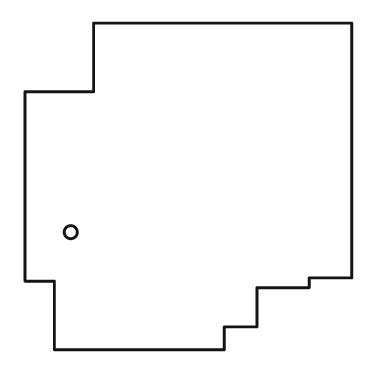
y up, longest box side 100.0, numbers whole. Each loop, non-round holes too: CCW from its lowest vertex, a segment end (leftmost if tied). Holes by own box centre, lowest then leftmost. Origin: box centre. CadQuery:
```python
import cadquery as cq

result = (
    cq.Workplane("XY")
    .moveTo(-41.0, -50.0)
    .lineTo(11.0, -50.0)
    .lineTo(11.0, -43.0)
    .lineTo(21.0, -43.0)
    .lineTo(21.0, -31.0)
    .lineTo(37.0, -31.0)
    .lineTo(37.0, -28.0)
    .lineTo(50.0, -28.0)
    .lineTo(50.0, 50.0)
    .lineTo(-29.0, 50.0)
    .lineTo(-29.0, 29.0)
    .lineTo(-50.0, 29.0)
    .lineTo(-50.0, -29.0)
    .lineTo(-41.0, -29.0)
    .close()
    .moveTo(-36.0, -14.0)
    .circle(2.0)
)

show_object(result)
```